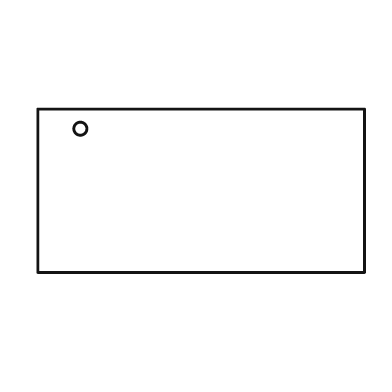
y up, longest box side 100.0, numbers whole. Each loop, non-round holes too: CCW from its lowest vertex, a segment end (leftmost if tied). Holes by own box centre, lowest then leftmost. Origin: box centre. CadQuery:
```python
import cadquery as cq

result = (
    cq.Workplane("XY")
    .moveTo(-50.0, -25.0)
    .lineTo(50.0, -25.0)
    .lineTo(50.0, 25.0)
    .lineTo(-50.0, 25.0)
    .close()
    .moveTo(-37.0, 19.0)
    .circle(2.0)
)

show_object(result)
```